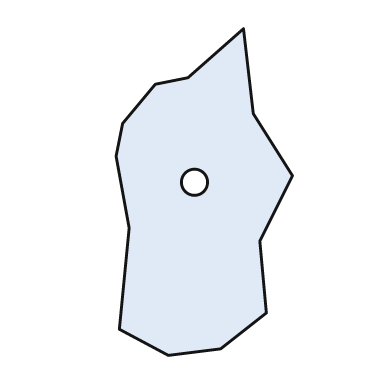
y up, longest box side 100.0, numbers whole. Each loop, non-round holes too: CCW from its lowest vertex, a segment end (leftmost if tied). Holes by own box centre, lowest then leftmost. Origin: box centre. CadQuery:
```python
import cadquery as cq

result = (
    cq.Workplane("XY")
    .moveTo(-11.0, -50.0)
    .lineTo(5.0, -48.0)
    .lineTo(19.0, -37.0)
    .lineTo(17.0, -15.0)
    .lineTo(27.0, 5.0)
    .lineTo(15.0, 24.0)
    .lineTo(12.0, 50.0)
    .lineTo(-5.0, 35.0)
    .lineTo(-15.0, 33.0)
    .lineTo(-25.0, 21.0)
    .lineTo(-27.0, 11.0)
    .lineTo(-23.0, -11.0)
    .lineTo(-26.0, -42.0)
    .close()
    .moveTo(-3.0, 3.0)
    .circle(4.0)
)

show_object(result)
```